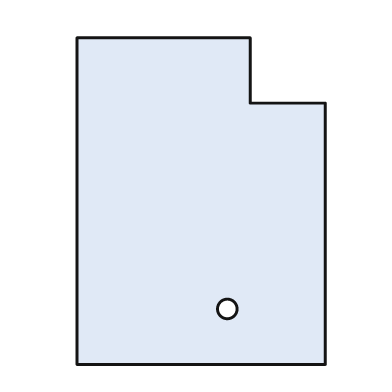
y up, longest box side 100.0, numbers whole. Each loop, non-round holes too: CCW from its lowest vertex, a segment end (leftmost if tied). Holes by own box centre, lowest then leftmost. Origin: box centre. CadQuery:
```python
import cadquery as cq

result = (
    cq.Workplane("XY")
    .moveTo(-38.0, -50.0)
    .lineTo(38.0, -50.0)
    .lineTo(38.0, 30.0)
    .lineTo(15.0, 30.0)
    .lineTo(15.0, 50.0)
    .lineTo(-38.0, 50.0)
    .close()
    .moveTo(8.0, -33.0)
    .circle(3.0)
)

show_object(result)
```